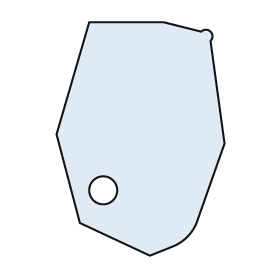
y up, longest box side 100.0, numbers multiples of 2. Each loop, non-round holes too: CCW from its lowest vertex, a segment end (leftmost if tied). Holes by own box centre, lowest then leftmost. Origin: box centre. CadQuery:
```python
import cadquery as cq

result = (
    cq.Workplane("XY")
    .moveTo(4.0, -50.0)
    .lineTo(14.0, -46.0)
    .threePointArc((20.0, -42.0), (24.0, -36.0))
    .lineTo(36.0, -2.0)
    .lineTo(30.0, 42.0)
    .threePointArc((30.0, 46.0), (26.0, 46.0))
    .lineTo(10.0, 50.0)
    .lineTo(-22.0, 50.0)
    .lineTo(-36.0, 2.0)
    .lineTo(-26.0, -36.0)
    .close()
    .moveTo(-16.0, -22.0)
    .circle(6.0)
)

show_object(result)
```